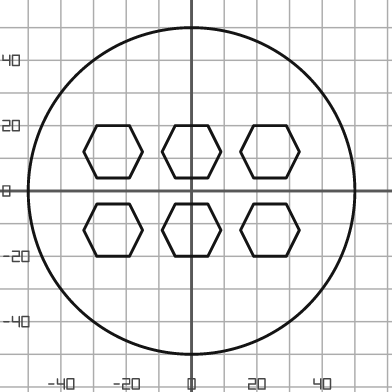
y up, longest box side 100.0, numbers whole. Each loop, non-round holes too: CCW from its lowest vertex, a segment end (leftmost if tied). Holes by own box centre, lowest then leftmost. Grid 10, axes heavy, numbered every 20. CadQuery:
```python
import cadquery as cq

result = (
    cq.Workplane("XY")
    .moveTo(0.0, 0.0)
    .circle(50.0)
    .moveTo(-29.0, -20.0)
    .lineTo(-19.0, -20.0)
    .lineTo(-15.0, -12.0)
    .lineTo(-19.0, -4.0)
    .lineTo(-29.0, -4.0)
    .lineTo(-33.0, -12.0)
    .close()
    .moveTo(-5.0, -20.0)
    .lineTo(5.0, -20.0)
    .lineTo(9.0, -12.0)
    .lineTo(5.0, -4.0)
    .lineTo(-5.0, -4.0)
    .lineTo(-9.0, -12.0)
    .close()
    .moveTo(19.0, -20.0)
    .lineTo(29.0, -20.0)
    .lineTo(33.0, -12.0)
    .lineTo(29.0, -4.0)
    .lineTo(19.0, -4.0)
    .lineTo(15.0, -12.0)
    .close()
    .moveTo(-29.0, 4.0)
    .lineTo(-19.0, 4.0)
    .lineTo(-15.0, 12.0)
    .lineTo(-19.0, 20.0)
    .lineTo(-29.0, 20.0)
    .lineTo(-33.0, 12.0)
    .close()
    .moveTo(-5.0, 4.0)
    .lineTo(5.0, 4.0)
    .lineTo(9.0, 12.0)
    .lineTo(5.0, 20.0)
    .lineTo(-5.0, 20.0)
    .lineTo(-9.0, 12.0)
    .close()
    .moveTo(19.0, 4.0)
    .lineTo(29.0, 4.0)
    .lineTo(33.0, 12.0)
    .lineTo(29.0, 20.0)
    .lineTo(19.0, 20.0)
    .lineTo(15.0, 12.0)
    .close()
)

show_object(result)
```